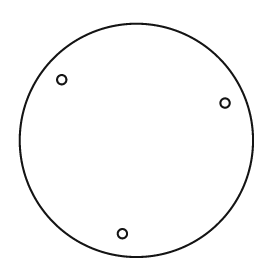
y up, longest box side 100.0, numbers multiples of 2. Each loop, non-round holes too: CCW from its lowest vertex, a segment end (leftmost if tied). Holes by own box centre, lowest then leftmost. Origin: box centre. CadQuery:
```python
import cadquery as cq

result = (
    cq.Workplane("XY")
    .moveTo(0.0, 0.0)
    .circle(50.0)
    .moveTo(-6.0, -40.0)
    .circle(2.0)
    .moveTo(38.0, 16.0)
    .circle(2.0)
    .moveTo(-32.0, 26.0)
    .circle(2.0)
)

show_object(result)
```